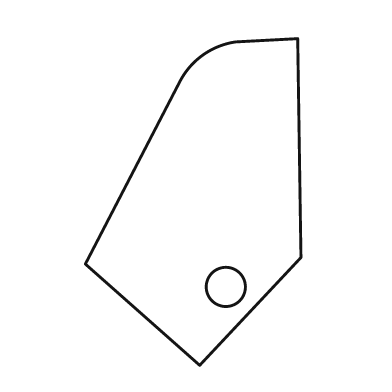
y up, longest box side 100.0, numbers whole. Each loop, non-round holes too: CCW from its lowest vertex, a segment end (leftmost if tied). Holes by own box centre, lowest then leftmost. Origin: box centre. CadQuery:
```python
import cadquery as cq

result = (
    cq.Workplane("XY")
    .moveTo(2.0, -50.0)
    .lineTo(33.0, -17.0)
    .lineTo(32.0, 50.0)
    .lineTo(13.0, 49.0)
    .threePointArc((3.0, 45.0), (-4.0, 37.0))
    .lineTo(-33.0, -19.0)
    .close()
    .moveTo(10.0, -26.0)
    .circle(6.0)
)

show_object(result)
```